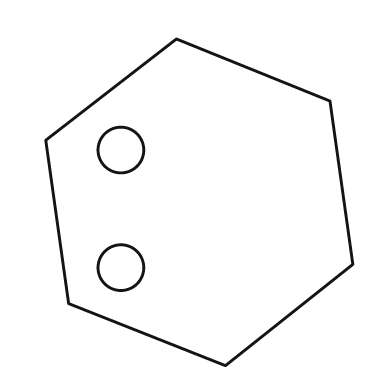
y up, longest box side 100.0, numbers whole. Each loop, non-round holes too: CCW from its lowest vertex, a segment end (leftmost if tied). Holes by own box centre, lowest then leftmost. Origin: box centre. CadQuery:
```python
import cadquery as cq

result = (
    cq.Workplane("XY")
    .moveTo(8.0, -50.0)
    .lineTo(47.0, -19.0)
    .lineTo(40.0, 31.0)
    .lineTo(-7.0, 50.0)
    .lineTo(-47.0, 19.0)
    .lineTo(-40.0, -31.0)
    .close()
    .moveTo(-24.0, -20.0)
    .circle(7.0)
    .moveTo(-24.0, 16.0)
    .circle(7.0)
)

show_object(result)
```